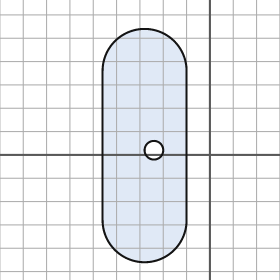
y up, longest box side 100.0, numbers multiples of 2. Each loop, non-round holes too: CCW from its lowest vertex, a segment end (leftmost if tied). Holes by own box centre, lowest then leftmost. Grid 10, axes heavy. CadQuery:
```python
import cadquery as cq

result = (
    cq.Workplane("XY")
    .moveTo(-46.0, -28.0)
    .threePointArc((-28.0, -46.0), (-10.0, -28.0))
    .lineTo(-10.0, 36.0)
    .threePointArc((-28.0, 54.0), (-46.0, 36.0))
    .close()
    .moveTo(-24.0, 2.0)
    .circle(4.0)
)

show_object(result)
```